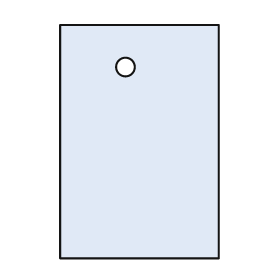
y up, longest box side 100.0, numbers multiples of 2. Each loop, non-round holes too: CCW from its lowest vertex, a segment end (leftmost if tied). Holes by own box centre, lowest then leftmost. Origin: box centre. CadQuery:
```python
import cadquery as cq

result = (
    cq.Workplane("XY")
    .moveTo(-34.0, -50.0)
    .lineTo(34.0, -50.0)
    .lineTo(34.0, 50.0)
    .lineTo(-34.0, 50.0)
    .close()
    .moveTo(-6.0, 32.0)
    .circle(4.0)
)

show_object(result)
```